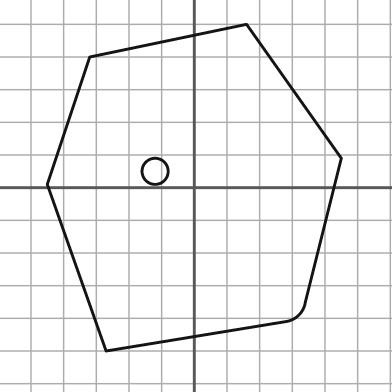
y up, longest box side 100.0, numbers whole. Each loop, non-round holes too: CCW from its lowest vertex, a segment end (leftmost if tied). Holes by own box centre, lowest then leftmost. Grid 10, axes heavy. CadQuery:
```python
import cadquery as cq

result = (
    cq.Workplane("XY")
    .moveTo(-27.0, -50.0)
    .lineTo(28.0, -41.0)
    .threePointArc((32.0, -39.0), (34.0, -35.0))
    .lineTo(45.0, 9.0)
    .lineTo(16.0, 50.0)
    .lineTo(-32.0, 40.0)
    .lineTo(-45.0, 1.0)
    .close()
    .moveTo(-12.0, 5.0)
    .circle(4.0)
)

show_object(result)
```